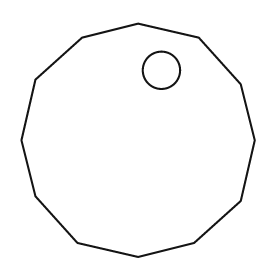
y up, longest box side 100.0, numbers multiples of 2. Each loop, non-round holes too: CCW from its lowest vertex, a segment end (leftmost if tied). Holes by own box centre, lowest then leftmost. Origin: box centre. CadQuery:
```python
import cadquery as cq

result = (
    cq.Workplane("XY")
    .moveTo(0.0, -50.0)
    .lineTo(24.0, -44.0)
    .lineTo(44.0, -26.0)
    .lineTo(50.0, 0.0)
    .lineTo(44.0, 24.0)
    .lineTo(26.0, 44.0)
    .lineTo(0.0, 50.0)
    .lineTo(-24.0, 44.0)
    .lineTo(-44.0, 26.0)
    .lineTo(-50.0, 0.0)
    .lineTo(-44.0, -24.0)
    .lineTo(-26.0, -44.0)
    .close()
    .moveTo(10.0, 30.0)
    .circle(8.0)
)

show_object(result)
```